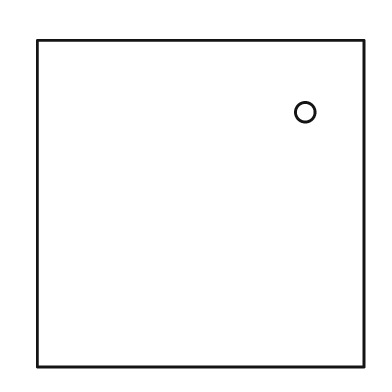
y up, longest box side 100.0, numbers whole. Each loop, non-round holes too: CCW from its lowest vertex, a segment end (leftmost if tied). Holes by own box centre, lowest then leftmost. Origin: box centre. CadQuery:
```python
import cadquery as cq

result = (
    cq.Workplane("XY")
    .moveTo(-50.0, -50.0)
    .lineTo(50.0, -50.0)
    .lineTo(50.0, 50.0)
    .lineTo(-50.0, 50.0)
    .close()
    .moveTo(32.0, 28.0)
    .circle(3.0)
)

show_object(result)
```